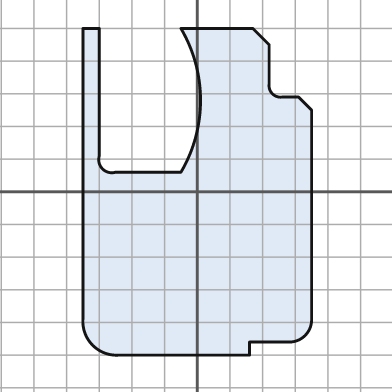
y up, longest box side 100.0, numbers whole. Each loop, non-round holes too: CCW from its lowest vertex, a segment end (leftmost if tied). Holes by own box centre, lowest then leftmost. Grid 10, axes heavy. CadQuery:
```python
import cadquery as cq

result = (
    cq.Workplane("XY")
    .moveTo(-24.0, -50.0)
    .lineTo(16.0, -50.0)
    .lineTo(16.0, -46.0)
    .lineTo(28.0, -46.0)
    .threePointArc((33.0, -44.0), (35.0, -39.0))
    .lineTo(35.0, 25.0)
    .lineTo(31.0, 29.0)
    .lineTo(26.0, 29.0)
    .threePointArc((23.0, 30.0), (22.0, 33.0))
    .lineTo(22.0, 45.0)
    .lineTo(17.0, 50.0)
    .lineTo(-5.0, 50.0)
    .threePointArc((1.0, 28.0), (-5.0, 6.0))
    .lineTo(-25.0, 6.0)
    .threePointArc((-29.0, 7.0), (-30.0, 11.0))
    .lineTo(-30.0, 50.0)
    .lineTo(-35.0, 50.0)
    .lineTo(-35.0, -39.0)
    .threePointArc((-32.0, -47.0), (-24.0, -50.0))
    .close()
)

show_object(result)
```